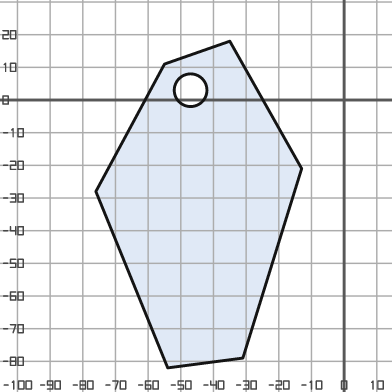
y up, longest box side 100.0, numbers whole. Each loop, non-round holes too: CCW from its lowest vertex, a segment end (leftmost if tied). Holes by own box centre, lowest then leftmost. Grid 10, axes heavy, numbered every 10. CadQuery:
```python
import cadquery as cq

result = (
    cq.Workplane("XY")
    .moveTo(-54.0, -82.0)
    .lineTo(-31.0, -79.0)
    .lineTo(-13.0, -21.0)
    .lineTo(-35.0, 18.0)
    .lineTo(-55.0, 11.0)
    .lineTo(-76.0, -28.0)
    .close()
    .moveTo(-47.0, 3.0)
    .circle(5.0)
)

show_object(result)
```